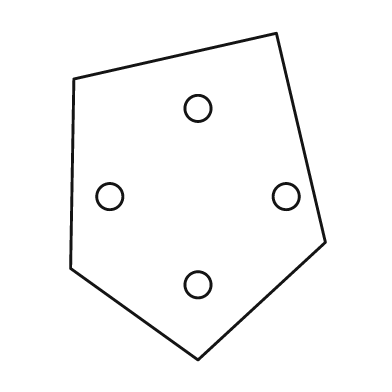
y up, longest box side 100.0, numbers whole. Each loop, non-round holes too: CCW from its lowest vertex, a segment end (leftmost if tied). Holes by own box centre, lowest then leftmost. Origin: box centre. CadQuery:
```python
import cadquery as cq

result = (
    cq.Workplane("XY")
    .moveTo(0.0, -50.0)
    .lineTo(39.0, -14.0)
    .lineTo(24.0, 50.0)
    .lineTo(-38.0, 36.0)
    .lineTo(-39.0, -22.0)
    .close()
    .moveTo(0.0, -27.0)
    .circle(4.0)
    .moveTo(-27.0, 0.0)
    .circle(4.0)
    .moveTo(27.0, 0.0)
    .circle(4.0)
    .moveTo(0.0, 27.0)
    .circle(4.0)
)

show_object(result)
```